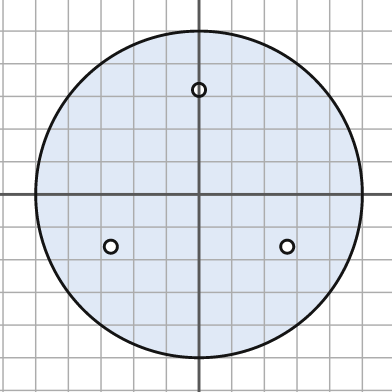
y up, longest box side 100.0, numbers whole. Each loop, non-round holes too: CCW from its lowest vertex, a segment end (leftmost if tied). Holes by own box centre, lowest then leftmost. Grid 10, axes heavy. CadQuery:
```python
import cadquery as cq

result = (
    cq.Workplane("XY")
    .moveTo(0.0, 0.0)
    .circle(50.0)
    .moveTo(-27.0, -16.0)
    .circle(2.0)
    .moveTo(27.0, -16.0)
    .circle(2.0)
    .moveTo(0.0, 32.0)
    .circle(2.0)
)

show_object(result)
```